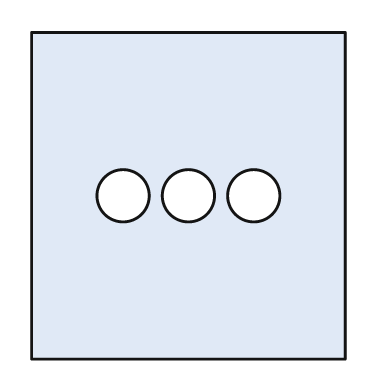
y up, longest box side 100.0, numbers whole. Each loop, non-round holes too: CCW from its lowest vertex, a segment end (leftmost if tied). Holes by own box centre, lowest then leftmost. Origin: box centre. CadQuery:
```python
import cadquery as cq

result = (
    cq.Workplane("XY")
    .moveTo(-48.0, -50.0)
    .lineTo(48.0, -50.0)
    .lineTo(48.0, 50.0)
    .lineTo(-48.0, 50.0)
    .close()
    .moveTo(-20.0, 0.0)
    .circle(8.0)
    .moveTo(0.0, 0.0)
    .circle(8.0)
    .moveTo(20.0, 0.0)
    .circle(8.0)
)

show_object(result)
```